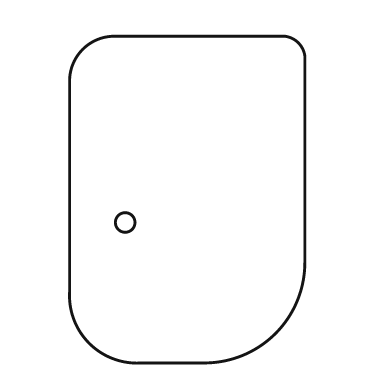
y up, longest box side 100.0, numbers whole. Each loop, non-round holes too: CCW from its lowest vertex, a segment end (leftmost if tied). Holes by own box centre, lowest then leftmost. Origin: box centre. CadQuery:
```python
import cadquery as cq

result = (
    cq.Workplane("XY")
    .moveTo(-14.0, -50.0)
    .lineTo(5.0, -50.0)
    .threePointArc((27.0, -41.0), (36.0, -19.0))
    .lineTo(36.0, 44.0)
    .threePointArc((34.0, 48.0), (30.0, 50.0))
    .lineTo(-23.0, 50.0)
    .threePointArc((-32.0, 46.0), (-36.0, 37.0))
    .lineTo(-36.0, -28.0)
    .threePointArc((-30.0, -44.0), (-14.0, -50.0))
    .close()
    .moveTo(-19.0, -7.0)
    .circle(3.0)
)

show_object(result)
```